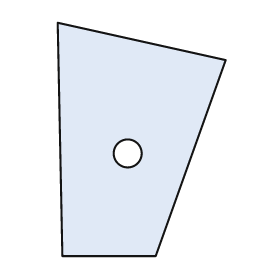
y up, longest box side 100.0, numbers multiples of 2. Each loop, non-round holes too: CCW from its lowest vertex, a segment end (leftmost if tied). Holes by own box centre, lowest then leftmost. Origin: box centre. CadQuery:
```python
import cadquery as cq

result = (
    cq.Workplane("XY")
    .moveTo(-34.0, -50.0)
    .lineTo(6.0, -50.0)
    .lineTo(36.0, 34.0)
    .lineTo(-36.0, 50.0)
    .close()
    .moveTo(-6.0, -6.0)
    .circle(6.0)
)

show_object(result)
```